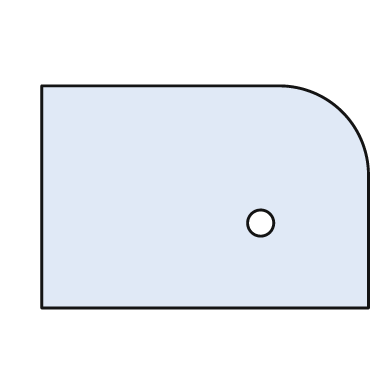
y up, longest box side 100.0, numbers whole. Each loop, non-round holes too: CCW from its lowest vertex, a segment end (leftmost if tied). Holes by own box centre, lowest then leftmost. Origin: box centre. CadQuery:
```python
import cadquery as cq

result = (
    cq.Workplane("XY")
    .moveTo(-50.0, -34.0)
    .lineTo(50.0, -34.0)
    .lineTo(50.0, 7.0)
    .threePointArc((42.0, 26.0), (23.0, 34.0))
    .lineTo(-50.0, 34.0)
    .close()
    .moveTo(17.0, -8.0)
    .circle(4.0)
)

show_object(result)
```